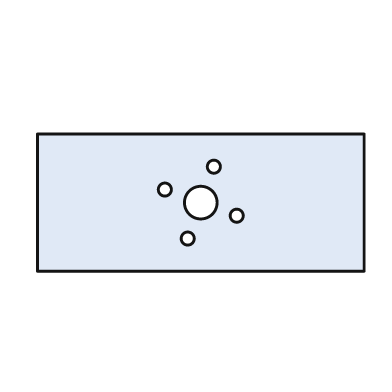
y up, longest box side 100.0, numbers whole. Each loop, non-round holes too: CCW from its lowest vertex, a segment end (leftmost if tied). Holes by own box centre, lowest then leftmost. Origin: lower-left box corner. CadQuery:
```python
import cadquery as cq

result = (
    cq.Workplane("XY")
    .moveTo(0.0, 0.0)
    .lineTo(100.0, 0.0)
    .lineTo(100.0, 42.0)
    .lineTo(0.0, 42.0)
    .close()
    .moveTo(46.0, 10.0)
    .circle(2.0)
    .moveTo(61.0, 17.0)
    .circle(2.0)
    .moveTo(50.0, 21.0)
    .circle(5.0)
    .moveTo(39.0, 25.0)
    .circle(2.0)
    .moveTo(54.0, 32.0)
    .circle(2.0)
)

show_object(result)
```